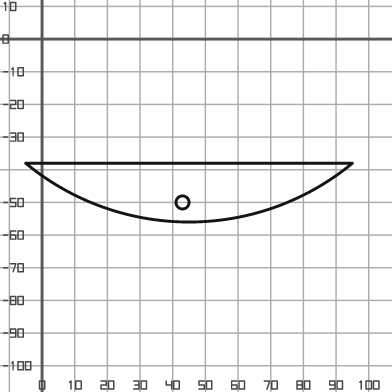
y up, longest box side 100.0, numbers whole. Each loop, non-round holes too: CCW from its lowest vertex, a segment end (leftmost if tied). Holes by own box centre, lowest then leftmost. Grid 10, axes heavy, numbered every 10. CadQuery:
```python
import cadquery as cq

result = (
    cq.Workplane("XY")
    .moveTo(-5.0, -38.0)
    .threePointArc((45.0, -56.0), (95.0, -38.0))
    .close()
    .moveTo(43.0, -50.0)
    .circle(2.0)
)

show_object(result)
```